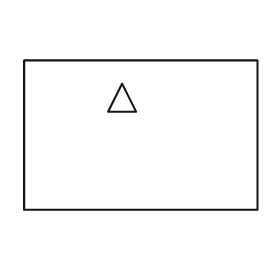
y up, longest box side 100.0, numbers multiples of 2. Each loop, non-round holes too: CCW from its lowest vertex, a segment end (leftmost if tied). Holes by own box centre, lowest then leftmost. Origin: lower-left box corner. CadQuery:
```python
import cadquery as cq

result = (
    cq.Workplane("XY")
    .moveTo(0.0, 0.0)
    .lineTo(100.0, 0.0)
    .lineTo(100.0, 64.0)
    .lineTo(0.0, 64.0)
    .close()
    .moveTo(36.0, 42.0)
    .lineTo(48.0, 42.0)
    .lineTo(42.0, 54.0)
    .close()
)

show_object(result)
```